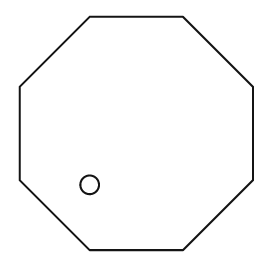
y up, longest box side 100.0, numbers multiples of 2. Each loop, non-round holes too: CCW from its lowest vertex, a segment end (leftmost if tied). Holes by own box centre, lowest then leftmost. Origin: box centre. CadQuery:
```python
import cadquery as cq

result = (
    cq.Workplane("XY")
    .moveTo(-20.0, -50.0)
    .lineTo(20.0, -50.0)
    .lineTo(50.0, -20.0)
    .lineTo(50.0, 20.0)
    .lineTo(20.0, 50.0)
    .lineTo(-20.0, 50.0)
    .lineTo(-50.0, 20.0)
    .lineTo(-50.0, -20.0)
    .close()
    .moveTo(-20.0, -22.0)
    .circle(4.0)
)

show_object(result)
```